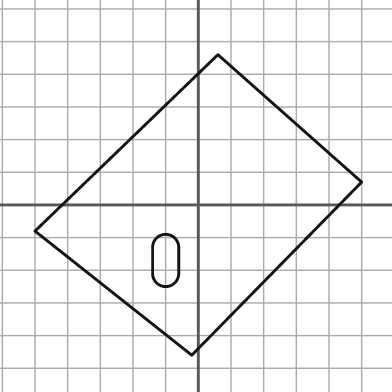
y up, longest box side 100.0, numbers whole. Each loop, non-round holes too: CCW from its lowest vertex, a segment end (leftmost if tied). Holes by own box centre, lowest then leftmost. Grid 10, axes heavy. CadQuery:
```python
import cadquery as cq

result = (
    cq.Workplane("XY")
    .moveTo(-2.0, -46.0)
    .lineTo(50.0, 7.0)
    .lineTo(6.0, 46.0)
    .lineTo(-50.0, -8.0)
    .close()
    .moveTo(-14.0, -21.0)
    .threePointArc((-10.0, -25.0), (-6.0, -21.0))
    .lineTo(-6.0, -13.0)
    .threePointArc((-10.0, -9.0), (-14.0, -13.0))
    .close()
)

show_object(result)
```